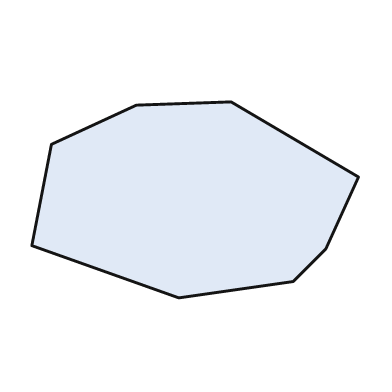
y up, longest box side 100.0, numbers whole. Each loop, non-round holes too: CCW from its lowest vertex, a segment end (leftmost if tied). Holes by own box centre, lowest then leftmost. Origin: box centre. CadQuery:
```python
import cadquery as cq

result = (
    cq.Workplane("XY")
    .moveTo(-5.0, -30.0)
    .lineTo(30.0, -25.0)
    .lineTo(40.0, -15.0)
    .lineTo(50.0, 7.0)
    .lineTo(11.0, 30.0)
    .lineTo(-18.0, 29.0)
    .lineTo(-44.0, 17.0)
    .lineTo(-50.0, -14.0)
    .close()
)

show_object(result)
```